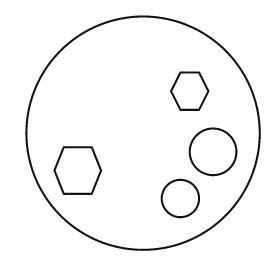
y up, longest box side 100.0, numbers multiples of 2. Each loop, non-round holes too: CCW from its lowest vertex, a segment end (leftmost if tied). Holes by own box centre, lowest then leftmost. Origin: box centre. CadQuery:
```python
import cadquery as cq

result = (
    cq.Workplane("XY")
    .moveTo(0.0, 0.0)
    .circle(50.0)
    .moveTo(16.0, -28.0)
    .circle(8.0)
    .moveTo(-34.0, -26.0)
    .lineTo(-22.0, -26.0)
    .lineTo(-18.0, -16.0)
    .lineTo(-22.0, -6.0)
    .lineTo(-34.0, -6.0)
    .lineTo(-38.0, -16.0)
    .close()
    .moveTo(30.0, -8.0)
    .circle(10.0)
    .moveTo(16.0, 10.0)
    .lineTo(24.0, 10.0)
    .lineTo(28.0, 18.0)
    .lineTo(24.0, 26.0)
    .lineTo(16.0, 26.0)
    .lineTo(12.0, 18.0)
    .close()
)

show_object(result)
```